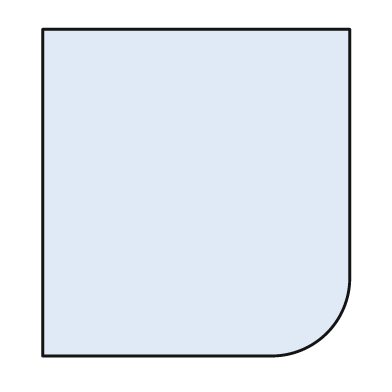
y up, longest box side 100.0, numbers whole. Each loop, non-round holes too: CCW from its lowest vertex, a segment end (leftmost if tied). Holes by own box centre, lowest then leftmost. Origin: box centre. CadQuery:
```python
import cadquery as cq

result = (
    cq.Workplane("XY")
    .moveTo(-47.0, -50.0)
    .lineTo(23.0, -50.0)
    .threePointArc((40.0, -43.0), (47.0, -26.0))
    .lineTo(47.0, 50.0)
    .lineTo(-47.0, 50.0)
    .close()
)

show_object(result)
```